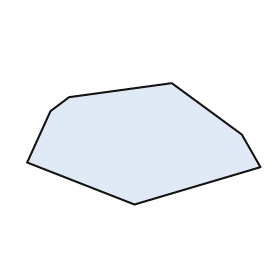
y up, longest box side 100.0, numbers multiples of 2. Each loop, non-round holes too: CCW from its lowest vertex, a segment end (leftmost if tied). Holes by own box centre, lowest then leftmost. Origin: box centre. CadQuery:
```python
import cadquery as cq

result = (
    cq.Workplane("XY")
    .moveTo(-4.0, -26.0)
    .lineTo(50.0, -10.0)
    .lineTo(42.0, 4.0)
    .lineTo(12.0, 26.0)
    .lineTo(-32.0, 20.0)
    .lineTo(-40.0, 14.0)
    .lineTo(-50.0, -8.0)
    .close()
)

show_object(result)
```